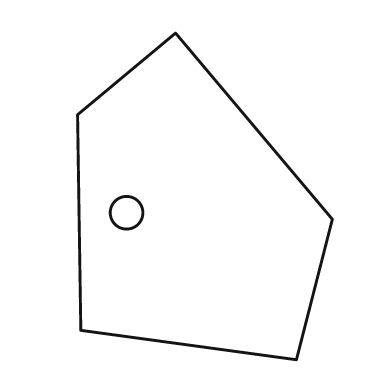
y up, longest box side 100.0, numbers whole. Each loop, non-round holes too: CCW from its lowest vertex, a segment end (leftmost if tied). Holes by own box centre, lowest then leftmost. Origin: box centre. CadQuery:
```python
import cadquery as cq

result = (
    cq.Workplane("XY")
    .moveTo(28.0, -50.0)
    .lineTo(39.0, -7.0)
    .lineTo(-9.0, 50.0)
    .lineTo(-39.0, 25.0)
    .lineTo(-38.0, -41.0)
    .close()
    .moveTo(-24.0, -5.0)
    .circle(5.0)
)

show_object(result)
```